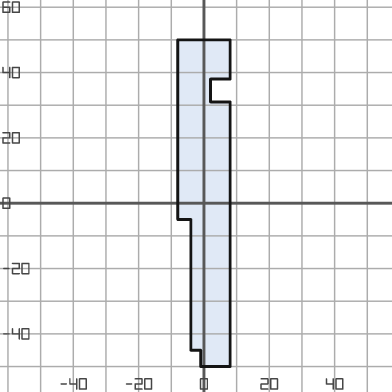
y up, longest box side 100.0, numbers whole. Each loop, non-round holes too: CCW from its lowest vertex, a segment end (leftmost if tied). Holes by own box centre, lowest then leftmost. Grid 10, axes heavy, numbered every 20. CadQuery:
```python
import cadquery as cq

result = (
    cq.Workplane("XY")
    .moveTo(-1.0, -50.0)
    .lineTo(8.0, -50.0)
    .lineTo(8.0, 31.0)
    .lineTo(2.0, 31.0)
    .lineTo(2.0, 38.0)
    .lineTo(8.0, 38.0)
    .lineTo(8.0, 50.0)
    .lineTo(-8.0, 50.0)
    .lineTo(-8.0, -5.0)
    .lineTo(-4.0, -5.0)
    .lineTo(-4.0, -45.0)
    .lineTo(-1.0, -45.0)
    .close()
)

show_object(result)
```